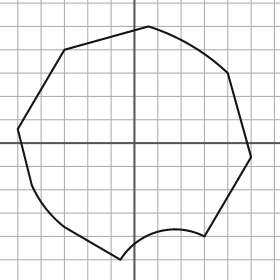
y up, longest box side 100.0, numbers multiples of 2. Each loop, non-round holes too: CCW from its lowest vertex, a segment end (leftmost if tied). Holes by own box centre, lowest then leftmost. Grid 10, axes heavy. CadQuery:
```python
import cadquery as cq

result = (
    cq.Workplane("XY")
    .moveTo(-6.0, -50.0)
    .threePointArc((10.0, -38.0), (30.0, -40.0))
    .lineTo(50.0, -6.0)
    .lineTo(40.0, 30.0)
    .threePointArc((24.0, 42.0), (6.0, 50.0))
    .lineTo(-30.0, 40.0)
    .lineTo(-50.0, 6.0)
    .lineTo(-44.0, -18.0)
    .threePointArc((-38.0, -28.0), (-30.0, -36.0))
    .close()
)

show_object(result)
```